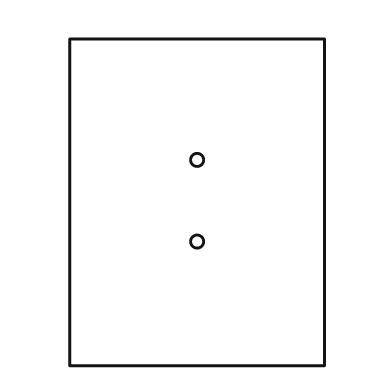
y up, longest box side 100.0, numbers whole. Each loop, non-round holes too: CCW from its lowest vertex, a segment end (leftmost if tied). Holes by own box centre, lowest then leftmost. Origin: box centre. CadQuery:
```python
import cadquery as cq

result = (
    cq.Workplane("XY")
    .moveTo(-39.0, -50.0)
    .lineTo(39.0, -50.0)
    .lineTo(39.0, 50.0)
    .lineTo(-39.0, 50.0)
    .close()
    .moveTo(0.0, -12.0)
    .circle(2.0)
    .moveTo(0.0, 13.0)
    .circle(2.0)
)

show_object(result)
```